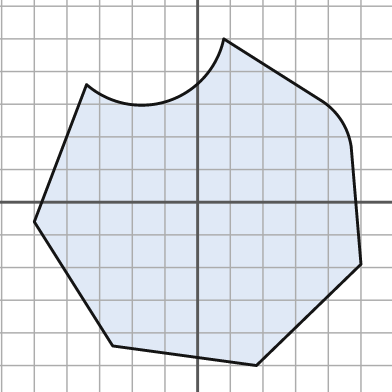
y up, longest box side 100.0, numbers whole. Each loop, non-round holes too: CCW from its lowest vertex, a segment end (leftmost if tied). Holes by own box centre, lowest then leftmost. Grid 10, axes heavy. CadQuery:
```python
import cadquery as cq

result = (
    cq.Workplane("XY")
    .moveTo(18.0, -50.0)
    .lineTo(50.0, -19.0)
    .lineTo(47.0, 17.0)
    .threePointArc((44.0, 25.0), (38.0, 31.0))
    .lineTo(8.0, 50.0)
    .threePointArc((-9.0, 31.0), (-34.0, 36.0))
    .lineTo(-50.0, -6.0)
    .lineTo(-26.0, -44.0)
    .close()
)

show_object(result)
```